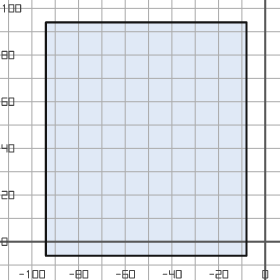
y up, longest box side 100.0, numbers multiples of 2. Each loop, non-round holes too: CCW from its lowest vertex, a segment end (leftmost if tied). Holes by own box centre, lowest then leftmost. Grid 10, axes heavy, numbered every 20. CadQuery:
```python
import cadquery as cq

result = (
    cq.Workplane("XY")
    .moveTo(-94.0, -6.0)
    .lineTo(-8.0, -6.0)
    .lineTo(-8.0, 94.0)
    .lineTo(-94.0, 94.0)
    .close()
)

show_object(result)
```